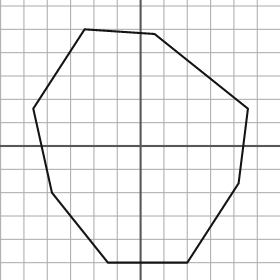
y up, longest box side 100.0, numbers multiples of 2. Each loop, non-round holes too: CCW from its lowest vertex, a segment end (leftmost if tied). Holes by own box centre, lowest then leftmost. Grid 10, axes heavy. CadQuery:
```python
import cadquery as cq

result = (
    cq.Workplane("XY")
    .moveTo(-14.0, -50.0)
    .lineTo(20.0, -50.0)
    .lineTo(42.0, -16.0)
    .lineTo(46.0, 16.0)
    .lineTo(6.0, 48.0)
    .lineTo(-24.0, 50.0)
    .lineTo(-46.0, 16.0)
    .lineTo(-38.0, -20.0)
    .close()
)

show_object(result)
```